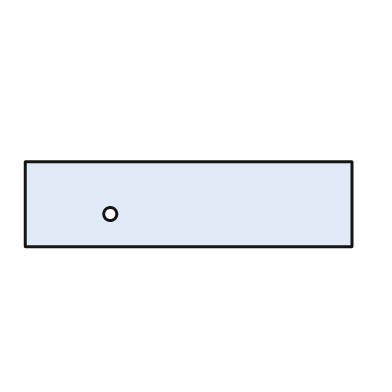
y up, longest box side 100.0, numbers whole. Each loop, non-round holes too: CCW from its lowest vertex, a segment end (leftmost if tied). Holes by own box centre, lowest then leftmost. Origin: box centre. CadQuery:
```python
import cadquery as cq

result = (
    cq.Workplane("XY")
    .moveTo(-50.0, -13.0)
    .lineTo(50.0, -13.0)
    .lineTo(50.0, 13.0)
    .lineTo(-50.0, 13.0)
    .close()
    .moveTo(-24.0, -3.0)
    .circle(2.0)
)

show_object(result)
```